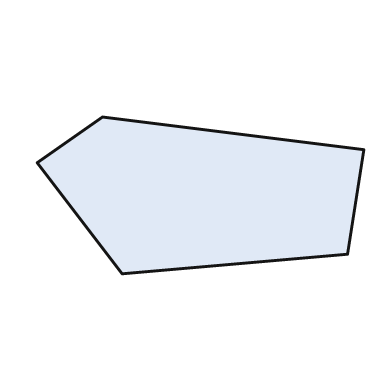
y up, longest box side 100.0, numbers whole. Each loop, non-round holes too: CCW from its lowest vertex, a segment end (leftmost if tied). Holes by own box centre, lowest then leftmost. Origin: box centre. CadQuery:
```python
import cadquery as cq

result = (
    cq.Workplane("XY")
    .moveTo(-24.0, -24.0)
    .lineTo(45.0, -18.0)
    .lineTo(50.0, 14.0)
    .lineTo(-30.0, 24.0)
    .lineTo(-50.0, 10.0)
    .close()
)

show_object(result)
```